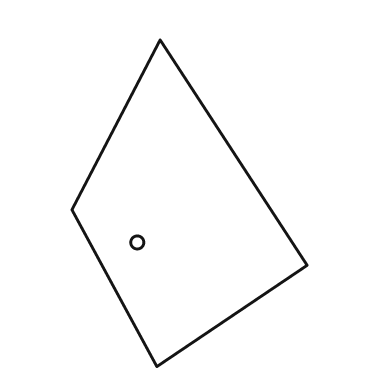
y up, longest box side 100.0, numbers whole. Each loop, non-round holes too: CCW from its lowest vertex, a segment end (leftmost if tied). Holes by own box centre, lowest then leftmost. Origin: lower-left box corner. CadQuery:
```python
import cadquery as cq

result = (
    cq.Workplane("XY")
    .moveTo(26.0, 0.0)
    .lineTo(72.0, 31.0)
    .lineTo(27.0, 100.0)
    .lineTo(0.0, 48.0)
    .close()
    .moveTo(20.0, 38.0)
    .circle(2.0)
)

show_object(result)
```